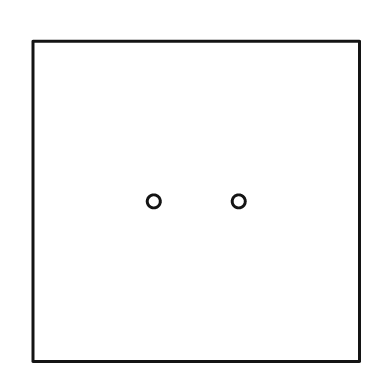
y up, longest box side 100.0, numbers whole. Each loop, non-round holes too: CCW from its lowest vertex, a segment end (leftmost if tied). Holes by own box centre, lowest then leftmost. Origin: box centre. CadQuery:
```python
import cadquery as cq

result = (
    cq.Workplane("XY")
    .moveTo(-50.0, -49.0)
    .lineTo(50.0, -49.0)
    .lineTo(50.0, 49.0)
    .lineTo(-50.0, 49.0)
    .close()
    .moveTo(-13.0, 0.0)
    .circle(2.0)
    .moveTo(13.0, 0.0)
    .circle(2.0)
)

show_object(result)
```